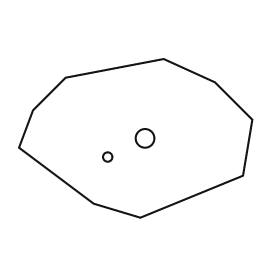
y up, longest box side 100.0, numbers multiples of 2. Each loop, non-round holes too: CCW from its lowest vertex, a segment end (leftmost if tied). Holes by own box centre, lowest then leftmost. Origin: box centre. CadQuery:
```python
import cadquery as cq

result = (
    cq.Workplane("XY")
    .moveTo(2.0, -34.0)
    .lineTo(46.0, -16.0)
    .lineTo(50.0, 8.0)
    .lineTo(34.0, 24.0)
    .lineTo(12.0, 34.0)
    .lineTo(-30.0, 26.0)
    .lineTo(-44.0, 12.0)
    .lineTo(-50.0, -4.0)
    .lineTo(-18.0, -28.0)
    .close()
    .moveTo(-12.0, -8.0)
    .circle(2.0)
    .moveTo(4.0, 0.0)
    .circle(4.0)
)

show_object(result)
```